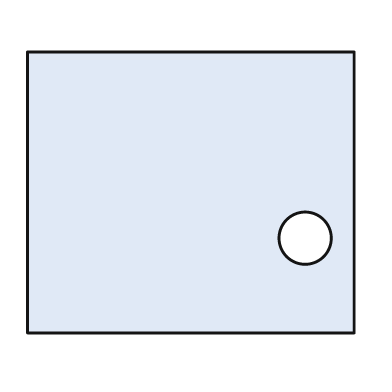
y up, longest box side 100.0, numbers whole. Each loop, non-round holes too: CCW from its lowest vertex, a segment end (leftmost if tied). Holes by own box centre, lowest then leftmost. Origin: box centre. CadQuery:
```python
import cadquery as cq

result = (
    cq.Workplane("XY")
    .moveTo(-50.0, -43.0)
    .lineTo(50.0, -43.0)
    .lineTo(50.0, 43.0)
    .lineTo(-50.0, 43.0)
    .close()
    .moveTo(35.0, -14.0)
    .circle(8.0)
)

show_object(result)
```